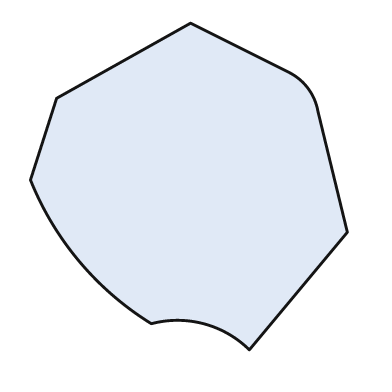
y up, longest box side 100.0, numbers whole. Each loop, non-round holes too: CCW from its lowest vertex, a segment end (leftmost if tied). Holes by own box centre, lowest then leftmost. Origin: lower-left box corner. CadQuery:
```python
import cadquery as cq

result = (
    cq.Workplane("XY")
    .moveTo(67.0, 0.0)
    .lineTo(97.0, 36.0)
    .lineTo(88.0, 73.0)
    .threePointArc((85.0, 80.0), (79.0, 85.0))
    .lineTo(49.0, 100.0)
    .lineTo(8.0, 77.0)
    .lineTo(0.0, 52.0)
    .threePointArc((15.0, 27.0), (37.0, 8.0))
    .threePointArc((53.0, 8.0), (67.0, 0.0))
    .close()
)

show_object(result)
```